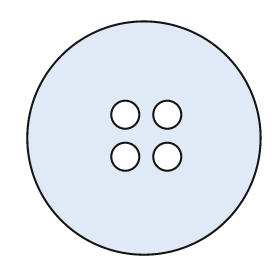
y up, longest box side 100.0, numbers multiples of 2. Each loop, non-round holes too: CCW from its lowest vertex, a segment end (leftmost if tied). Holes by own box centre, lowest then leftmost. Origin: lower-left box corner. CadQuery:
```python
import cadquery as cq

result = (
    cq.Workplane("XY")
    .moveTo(50.0, 50.0)
    .circle(50.0)
    .moveTo(42.0, 42.0)
    .circle(6.0)
    .moveTo(60.0, 42.0)
    .circle(6.0)
    .moveTo(42.0, 60.0)
    .circle(6.0)
    .moveTo(60.0, 60.0)
    .circle(6.0)
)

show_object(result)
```